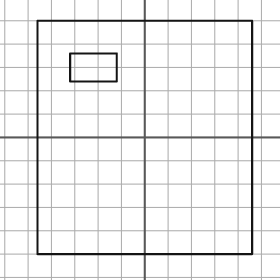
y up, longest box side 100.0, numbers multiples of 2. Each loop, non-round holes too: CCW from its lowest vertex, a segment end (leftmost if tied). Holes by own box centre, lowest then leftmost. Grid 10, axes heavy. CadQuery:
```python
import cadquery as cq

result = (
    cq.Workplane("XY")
    .moveTo(-46.0, -50.0)
    .lineTo(46.0, -50.0)
    .lineTo(46.0, 50.0)
    .lineTo(-46.0, 50.0)
    .close()
    .moveTo(-32.0, 24.0)
    .lineTo(-12.0, 24.0)
    .lineTo(-12.0, 36.0)
    .lineTo(-32.0, 36.0)
    .close()
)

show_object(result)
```